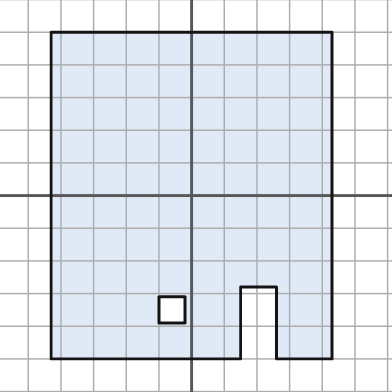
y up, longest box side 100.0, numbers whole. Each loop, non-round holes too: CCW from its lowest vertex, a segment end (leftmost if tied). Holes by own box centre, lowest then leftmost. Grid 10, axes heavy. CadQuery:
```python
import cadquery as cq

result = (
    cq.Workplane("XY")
    .moveTo(-43.0, -50.0)
    .lineTo(15.0, -50.0)
    .lineTo(15.0, -28.0)
    .lineTo(26.0, -28.0)
    .lineTo(26.0, -50.0)
    .lineTo(43.0, -50.0)
    .lineTo(43.0, 50.0)
    .lineTo(-43.0, 50.0)
    .close()
    .moveTo(-10.0, -39.0)
    .lineTo(-2.0, -39.0)
    .lineTo(-2.0, -31.0)
    .lineTo(-10.0, -31.0)
    .close()
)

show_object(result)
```